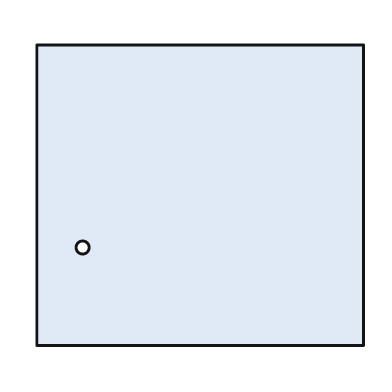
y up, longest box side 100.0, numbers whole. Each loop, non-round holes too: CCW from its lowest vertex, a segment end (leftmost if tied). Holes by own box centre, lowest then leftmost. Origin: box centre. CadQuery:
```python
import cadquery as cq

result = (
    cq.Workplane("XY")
    .moveTo(-50.0, -46.0)
    .lineTo(50.0, -46.0)
    .lineTo(50.0, 46.0)
    .lineTo(-50.0, 46.0)
    .close()
    .moveTo(-36.0, -16.0)
    .circle(2.0)
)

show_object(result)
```